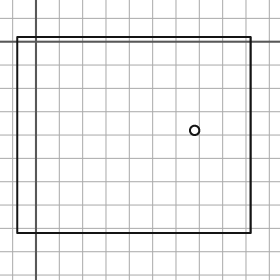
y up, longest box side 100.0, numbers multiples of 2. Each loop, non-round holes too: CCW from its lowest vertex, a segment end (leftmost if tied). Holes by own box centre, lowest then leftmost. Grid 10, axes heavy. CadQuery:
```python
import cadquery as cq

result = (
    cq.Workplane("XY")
    .moveTo(-8.0, -82.0)
    .lineTo(92.0, -82.0)
    .lineTo(92.0, 2.0)
    .lineTo(-8.0, 2.0)
    .close()
    .moveTo(68.0, -38.0)
    .circle(2.0)
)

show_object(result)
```